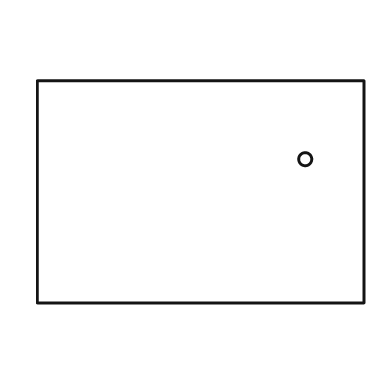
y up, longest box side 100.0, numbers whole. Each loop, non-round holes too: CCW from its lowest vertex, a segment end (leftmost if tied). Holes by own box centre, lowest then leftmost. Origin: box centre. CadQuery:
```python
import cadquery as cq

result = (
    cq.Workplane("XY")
    .moveTo(-50.0, -34.0)
    .lineTo(50.0, -34.0)
    .lineTo(50.0, 34.0)
    .lineTo(-50.0, 34.0)
    .close()
    .moveTo(32.0, 10.0)
    .circle(2.0)
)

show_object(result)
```